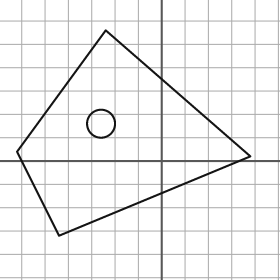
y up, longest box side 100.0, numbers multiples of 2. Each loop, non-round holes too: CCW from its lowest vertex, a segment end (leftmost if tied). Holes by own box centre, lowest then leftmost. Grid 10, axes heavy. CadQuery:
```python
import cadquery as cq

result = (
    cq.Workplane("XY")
    .moveTo(-44.0, -32.0)
    .lineTo(38.0, 2.0)
    .lineTo(-24.0, 56.0)
    .lineTo(-62.0, 4.0)
    .close()
    .moveTo(-26.0, 16.0)
    .circle(6.0)
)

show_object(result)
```